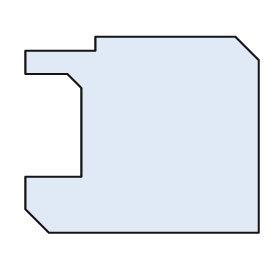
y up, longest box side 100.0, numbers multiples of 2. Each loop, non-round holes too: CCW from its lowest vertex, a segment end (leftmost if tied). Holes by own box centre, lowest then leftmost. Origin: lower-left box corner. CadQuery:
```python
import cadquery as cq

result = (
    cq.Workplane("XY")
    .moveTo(10.0, 0.0)
    .lineTo(100.0, 0.0)
    .lineTo(100.0, 74.0)
    .lineTo(90.0, 84.0)
    .lineTo(30.0, 84.0)
    .lineTo(30.0, 78.0)
    .lineTo(0.0, 78.0)
    .lineTo(0.0, 68.0)
    .lineTo(18.0, 68.0)
    .lineTo(24.0, 62.0)
    .lineTo(24.0, 24.0)
    .lineTo(0.0, 24.0)
    .lineTo(0.0, 10.0)
    .close()
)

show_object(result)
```